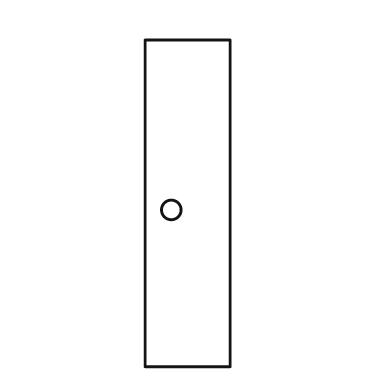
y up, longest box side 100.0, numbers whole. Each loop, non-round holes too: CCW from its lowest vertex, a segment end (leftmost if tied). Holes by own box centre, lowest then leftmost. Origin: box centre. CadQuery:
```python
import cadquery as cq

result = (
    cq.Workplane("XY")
    .moveTo(-13.0, -50.0)
    .lineTo(13.0, -50.0)
    .lineTo(13.0, 50.0)
    .lineTo(-13.0, 50.0)
    .close()
    .moveTo(-5.0, -2.0)
    .circle(3.0)
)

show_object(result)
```